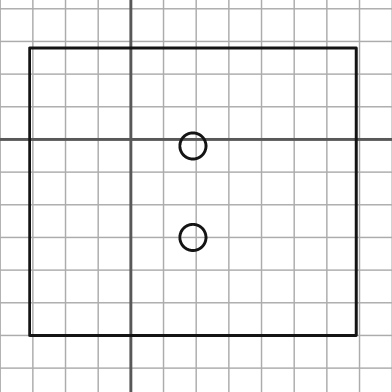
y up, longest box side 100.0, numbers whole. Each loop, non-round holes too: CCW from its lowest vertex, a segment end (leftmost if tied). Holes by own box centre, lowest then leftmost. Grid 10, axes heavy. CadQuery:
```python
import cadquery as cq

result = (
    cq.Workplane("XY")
    .moveTo(-31.0, -60.0)
    .lineTo(69.0, -60.0)
    .lineTo(69.0, 28.0)
    .lineTo(-31.0, 28.0)
    .close()
    .moveTo(19.0, -30.0)
    .circle(4.0)
    .moveTo(19.0, -2.0)
    .circle(4.0)
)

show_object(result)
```